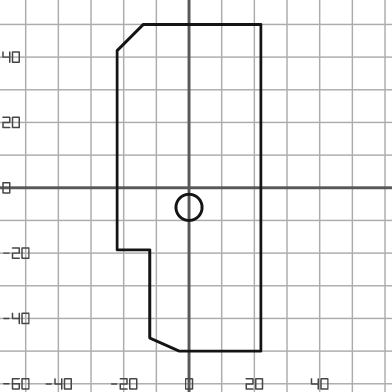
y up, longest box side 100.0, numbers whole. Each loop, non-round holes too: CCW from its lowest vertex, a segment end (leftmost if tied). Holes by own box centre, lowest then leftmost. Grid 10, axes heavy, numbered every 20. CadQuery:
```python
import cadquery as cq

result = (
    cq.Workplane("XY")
    .moveTo(-3.0, -50.0)
    .lineTo(22.0, -50.0)
    .lineTo(22.0, 50.0)
    .lineTo(-14.0, 50.0)
    .lineTo(-22.0, 42.0)
    .lineTo(-22.0, -19.0)
    .lineTo(-12.0, -19.0)
    .lineTo(-12.0, -46.0)
    .close()
    .moveTo(0.0, -6.0)
    .circle(4.0)
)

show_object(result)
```